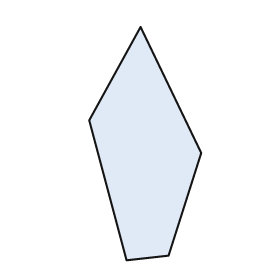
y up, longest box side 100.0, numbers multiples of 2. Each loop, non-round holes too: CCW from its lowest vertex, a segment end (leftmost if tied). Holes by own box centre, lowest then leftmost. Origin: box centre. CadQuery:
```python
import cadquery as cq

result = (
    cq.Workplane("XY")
    .moveTo(-8.0, -50.0)
    .lineTo(10.0, -48.0)
    .lineTo(24.0, -4.0)
    .lineTo(-2.0, 50.0)
    .lineTo(-24.0, 10.0)
    .close()
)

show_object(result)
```